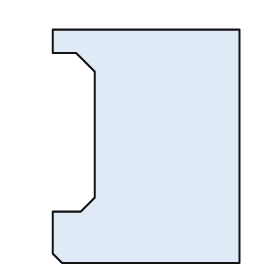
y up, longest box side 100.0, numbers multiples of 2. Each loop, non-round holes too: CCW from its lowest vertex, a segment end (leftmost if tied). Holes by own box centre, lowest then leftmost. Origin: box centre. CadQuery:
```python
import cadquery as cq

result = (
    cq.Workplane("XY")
    .moveTo(-36.0, -50.0)
    .lineTo(40.0, -50.0)
    .lineTo(40.0, 50.0)
    .lineTo(-40.0, 50.0)
    .lineTo(-40.0, 40.0)
    .lineTo(-30.0, 40.0)
    .lineTo(-22.0, 32.0)
    .lineTo(-22.0, -22.0)
    .lineTo(-28.0, -28.0)
    .lineTo(-40.0, -28.0)
    .lineTo(-40.0, -46.0)
    .close()
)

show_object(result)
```